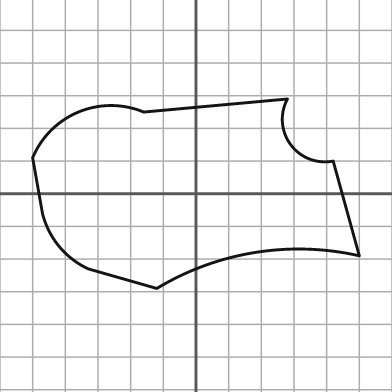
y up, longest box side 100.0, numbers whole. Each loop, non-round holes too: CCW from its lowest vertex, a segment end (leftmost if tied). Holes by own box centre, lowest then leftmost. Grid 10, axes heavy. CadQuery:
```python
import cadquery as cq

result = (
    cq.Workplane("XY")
    .moveTo(-12.0, -29.0)
    .threePointArc((18.0, -18.0), (50.0, -19.0))
    .lineTo(42.0, 10.0)
    .threePointArc((29.0, 15.0), (28.0, 29.0))
    .lineTo(-16.0, 25.0)
    .threePointArc((-36.0, 25.0), (-50.0, 11.0))
    .lineTo(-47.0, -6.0)
    .threePointArc((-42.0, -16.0), (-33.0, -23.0))
    .close()
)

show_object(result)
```